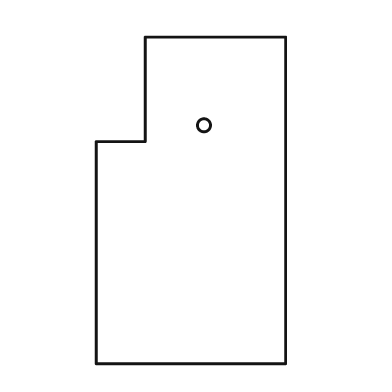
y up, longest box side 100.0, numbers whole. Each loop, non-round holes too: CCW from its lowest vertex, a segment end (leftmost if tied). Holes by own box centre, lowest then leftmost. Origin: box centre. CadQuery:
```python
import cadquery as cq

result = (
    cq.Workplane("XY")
    .moveTo(-29.0, -50.0)
    .lineTo(29.0, -50.0)
    .lineTo(29.0, 50.0)
    .lineTo(-14.0, 50.0)
    .lineTo(-14.0, 18.0)
    .lineTo(-29.0, 18.0)
    .close()
    .moveTo(4.0, 23.0)
    .circle(2.0)
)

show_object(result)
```